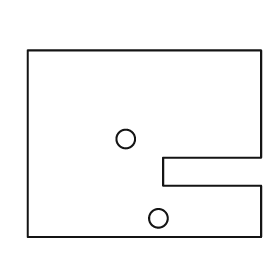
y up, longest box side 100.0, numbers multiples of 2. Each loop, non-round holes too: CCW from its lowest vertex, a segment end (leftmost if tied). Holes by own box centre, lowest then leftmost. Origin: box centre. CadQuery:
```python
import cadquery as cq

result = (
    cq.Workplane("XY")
    .moveTo(-50.0, -40.0)
    .lineTo(50.0, -40.0)
    .lineTo(50.0, -18.0)
    .lineTo(8.0, -18.0)
    .lineTo(8.0, -6.0)
    .lineTo(50.0, -6.0)
    .lineTo(50.0, 40.0)
    .lineTo(-50.0, 40.0)
    .close()
    .moveTo(6.0, -32.0)
    .circle(4.0)
    .moveTo(-8.0, 2.0)
    .circle(4.0)
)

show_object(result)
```